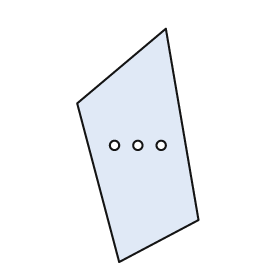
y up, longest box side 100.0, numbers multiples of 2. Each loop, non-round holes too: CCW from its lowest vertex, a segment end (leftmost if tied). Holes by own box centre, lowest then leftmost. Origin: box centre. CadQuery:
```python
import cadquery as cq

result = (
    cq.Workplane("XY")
    .moveTo(-8.0, -50.0)
    .lineTo(26.0, -32.0)
    .lineTo(12.0, 50.0)
    .lineTo(-26.0, 18.0)
    .close()
    .moveTo(-10.0, 0.0)
    .circle(2.0)
    .moveTo(0.0, 0.0)
    .circle(2.0)
    .moveTo(10.0, 0.0)
    .circle(2.0)
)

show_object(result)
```